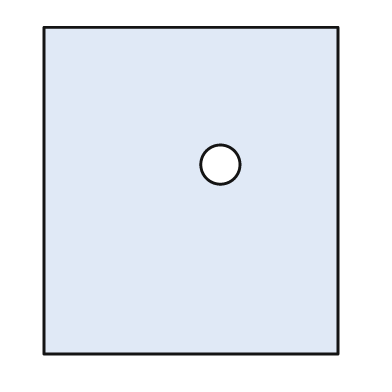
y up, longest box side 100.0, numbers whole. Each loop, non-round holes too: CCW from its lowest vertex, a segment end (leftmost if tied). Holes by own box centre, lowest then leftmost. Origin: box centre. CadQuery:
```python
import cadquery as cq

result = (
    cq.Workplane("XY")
    .moveTo(-45.0, -50.0)
    .lineTo(45.0, -50.0)
    .lineTo(45.0, 50.0)
    .lineTo(-45.0, 50.0)
    .close()
    .moveTo(9.0, 8.0)
    .circle(6.0)
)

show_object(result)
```